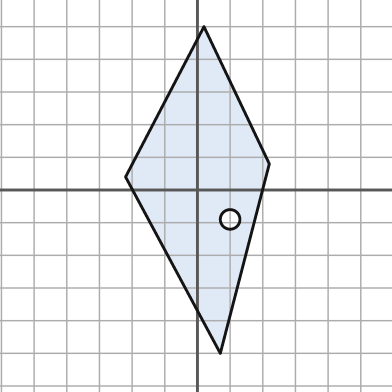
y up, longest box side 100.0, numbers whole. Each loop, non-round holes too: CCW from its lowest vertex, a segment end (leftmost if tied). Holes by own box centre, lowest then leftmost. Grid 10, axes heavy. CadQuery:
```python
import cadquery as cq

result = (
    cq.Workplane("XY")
    .moveTo(7.0, -50.0)
    .lineTo(22.0, 8.0)
    .lineTo(2.0, 50.0)
    .lineTo(-22.0, 4.0)
    .close()
    .moveTo(10.0, -9.0)
    .circle(3.0)
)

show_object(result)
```